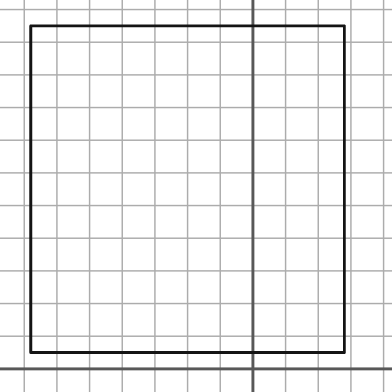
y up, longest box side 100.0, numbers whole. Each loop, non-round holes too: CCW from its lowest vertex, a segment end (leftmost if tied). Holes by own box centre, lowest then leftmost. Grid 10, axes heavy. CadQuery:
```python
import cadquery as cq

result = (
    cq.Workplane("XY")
    .moveTo(-68.0, 5.0)
    .lineTo(28.0, 5.0)
    .lineTo(28.0, 105.0)
    .lineTo(-68.0, 105.0)
    .close()
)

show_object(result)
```